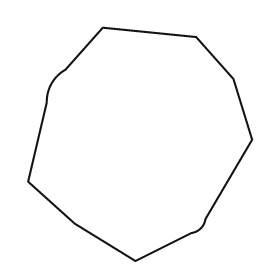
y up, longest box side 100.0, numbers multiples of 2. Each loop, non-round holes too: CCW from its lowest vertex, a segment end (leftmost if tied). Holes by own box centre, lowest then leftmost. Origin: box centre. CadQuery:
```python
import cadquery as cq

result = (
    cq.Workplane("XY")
    .moveTo(-2.0, -50.0)
    .lineTo(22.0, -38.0)
    .threePointArc((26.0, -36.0), (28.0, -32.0))
    .lineTo(48.0, 2.0)
    .lineTo(40.0, 28.0)
    .lineTo(24.0, 46.0)
    .lineTo(-16.0, 50.0)
    .lineTo(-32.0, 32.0)
    .threePointArc((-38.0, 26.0), (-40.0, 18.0))
    .lineTo(-48.0, -16.0)
    .lineTo(-28.0, -34.0)
    .close()
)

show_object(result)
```